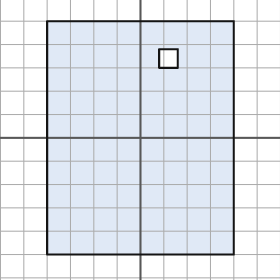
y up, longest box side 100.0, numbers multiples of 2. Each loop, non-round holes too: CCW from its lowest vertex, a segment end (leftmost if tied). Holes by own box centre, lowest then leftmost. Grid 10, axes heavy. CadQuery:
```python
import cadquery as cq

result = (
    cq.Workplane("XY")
    .moveTo(-40.0, -50.0)
    .lineTo(40.0, -50.0)
    .lineTo(40.0, 50.0)
    .lineTo(-40.0, 50.0)
    .close()
    .moveTo(8.0, 30.0)
    .lineTo(16.0, 30.0)
    .lineTo(16.0, 38.0)
    .lineTo(8.0, 38.0)
    .close()
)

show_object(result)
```